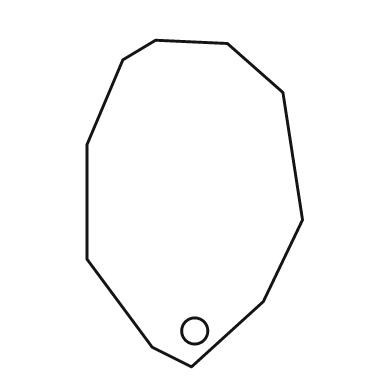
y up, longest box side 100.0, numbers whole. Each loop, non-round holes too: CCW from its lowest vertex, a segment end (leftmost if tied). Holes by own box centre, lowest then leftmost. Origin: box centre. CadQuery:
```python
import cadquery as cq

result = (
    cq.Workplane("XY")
    .moveTo(-1.0, -50.0)
    .lineTo(21.0, -30.0)
    .lineTo(33.0, -5.0)
    .lineTo(27.0, 34.0)
    .lineTo(10.0, 49.0)
    .lineTo(-12.0, 50.0)
    .lineTo(-22.0, 44.0)
    .lineTo(-33.0, 18.0)
    .lineTo(-33.0, -17.0)
    .lineTo(-13.0, -44.0)
    .close()
    .moveTo(0.0, -39.0)
    .circle(4.0)
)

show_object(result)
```